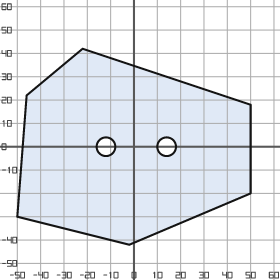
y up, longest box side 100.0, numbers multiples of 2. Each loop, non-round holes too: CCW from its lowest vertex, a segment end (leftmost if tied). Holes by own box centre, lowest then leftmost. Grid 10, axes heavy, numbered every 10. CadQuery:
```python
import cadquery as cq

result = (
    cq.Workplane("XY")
    .moveTo(-2.0, -42.0)
    .lineTo(50.0, -20.0)
    .lineTo(50.0, 18.0)
    .lineTo(-22.0, 42.0)
    .lineTo(-46.0, 22.0)
    .lineTo(-50.0, -30.0)
    .close()
    .moveTo(-12.0, 0.0)
    .circle(4.0)
    .moveTo(14.0, 0.0)
    .circle(4.0)
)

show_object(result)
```